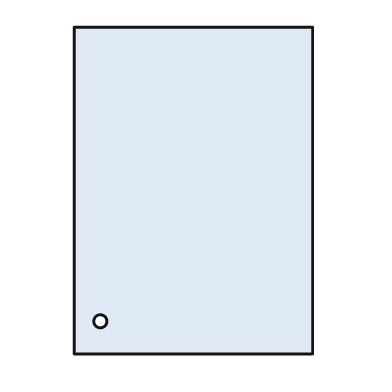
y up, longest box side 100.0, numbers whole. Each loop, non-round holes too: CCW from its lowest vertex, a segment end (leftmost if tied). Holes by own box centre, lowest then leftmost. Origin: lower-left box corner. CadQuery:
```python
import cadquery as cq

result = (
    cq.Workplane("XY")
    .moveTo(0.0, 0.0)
    .lineTo(73.0, 0.0)
    .lineTo(73.0, 100.0)
    .lineTo(0.0, 100.0)
    .close()
    .moveTo(8.0, 10.0)
    .circle(2.0)
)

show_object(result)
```